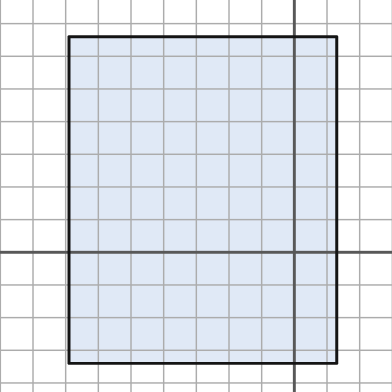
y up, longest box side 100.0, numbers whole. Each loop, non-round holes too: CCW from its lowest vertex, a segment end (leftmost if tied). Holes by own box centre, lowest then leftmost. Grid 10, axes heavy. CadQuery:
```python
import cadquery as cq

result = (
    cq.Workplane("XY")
    .moveTo(-69.0, -34.0)
    .lineTo(13.0, -34.0)
    .lineTo(13.0, 66.0)
    .lineTo(-69.0, 66.0)
    .close()
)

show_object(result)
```